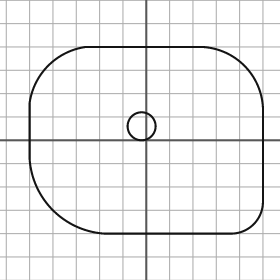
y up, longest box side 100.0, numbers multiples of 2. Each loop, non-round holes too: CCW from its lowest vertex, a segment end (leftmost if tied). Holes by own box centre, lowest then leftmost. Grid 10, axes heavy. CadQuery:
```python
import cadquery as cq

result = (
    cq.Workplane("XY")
    .moveTo(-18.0, -40.0)
    .lineTo(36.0, -40.0)
    .threePointArc((46.0, -36.0), (50.0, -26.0))
    .lineTo(50.0, 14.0)
    .threePointArc((42.0, 32.0), (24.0, 40.0))
    .lineTo(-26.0, 40.0)
    .threePointArc((-42.0, 32.0), (-50.0, 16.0))
    .lineTo(-50.0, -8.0)
    .threePointArc((-40.0, -30.0), (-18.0, -40.0))
    .close()
    .moveTo(-2.0, 6.0)
    .circle(6.0)
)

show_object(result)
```